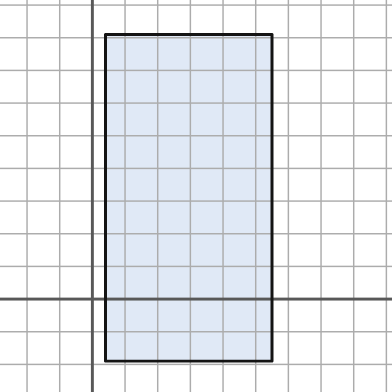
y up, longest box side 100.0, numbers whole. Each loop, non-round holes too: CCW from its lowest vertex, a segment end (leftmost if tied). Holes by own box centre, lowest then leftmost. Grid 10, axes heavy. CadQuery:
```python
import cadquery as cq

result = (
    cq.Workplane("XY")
    .moveTo(4.0, -19.0)
    .lineTo(55.0, -19.0)
    .lineTo(55.0, 81.0)
    .lineTo(4.0, 81.0)
    .close()
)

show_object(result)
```